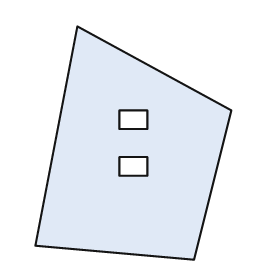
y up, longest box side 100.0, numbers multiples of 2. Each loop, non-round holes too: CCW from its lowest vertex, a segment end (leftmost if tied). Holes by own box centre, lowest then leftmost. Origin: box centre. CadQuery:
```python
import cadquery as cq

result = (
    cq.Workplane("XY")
    .moveTo(26.0, -50.0)
    .lineTo(42.0, 14.0)
    .lineTo(-24.0, 50.0)
    .lineTo(-42.0, -44.0)
    .close()
    .moveTo(-6.0, -14.0)
    .lineTo(6.0, -14.0)
    .lineTo(6.0, -6.0)
    .lineTo(-6.0, -6.0)
    .close()
    .moveTo(-6.0, 6.0)
    .lineTo(6.0, 6.0)
    .lineTo(6.0, 14.0)
    .lineTo(-6.0, 14.0)
    .close()
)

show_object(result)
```